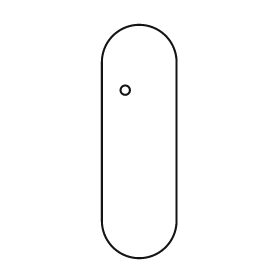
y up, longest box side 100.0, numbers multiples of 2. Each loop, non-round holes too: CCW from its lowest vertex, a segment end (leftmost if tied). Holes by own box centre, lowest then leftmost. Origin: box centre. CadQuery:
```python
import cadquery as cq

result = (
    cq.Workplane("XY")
    .moveTo(-16.0, -34.0)
    .threePointArc((0.0, -50.0), (16.0, -34.0))
    .lineTo(16.0, 34.0)
    .threePointArc((0.0, 50.0), (-16.0, 34.0))
    .close()
    .moveTo(-6.0, 22.0)
    .circle(2.0)
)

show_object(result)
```